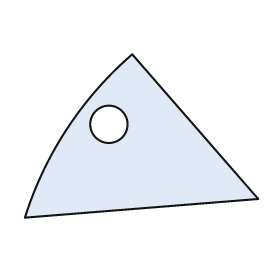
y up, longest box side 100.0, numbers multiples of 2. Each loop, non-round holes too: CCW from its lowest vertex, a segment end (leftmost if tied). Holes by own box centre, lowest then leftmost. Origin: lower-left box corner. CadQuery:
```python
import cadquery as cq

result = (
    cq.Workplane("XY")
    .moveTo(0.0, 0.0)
    .lineTo(100.0, 8.0)
    .lineTo(46.0, 70.0)
    .threePointArc((18.0, 38.0), (0.0, 0.0))
    .close()
    .moveTo(36.0, 40.0)
    .circle(8.0)
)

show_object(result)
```